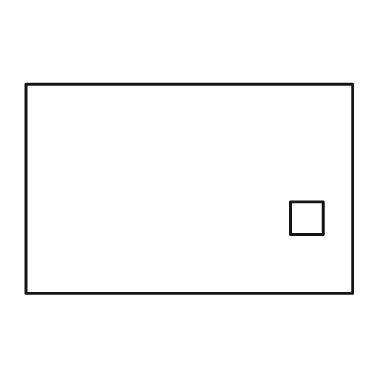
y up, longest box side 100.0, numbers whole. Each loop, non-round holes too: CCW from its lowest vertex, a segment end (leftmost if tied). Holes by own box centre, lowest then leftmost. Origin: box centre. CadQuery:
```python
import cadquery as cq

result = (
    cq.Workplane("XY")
    .moveTo(-50.0, -32.0)
    .lineTo(50.0, -32.0)
    .lineTo(50.0, 32.0)
    .lineTo(-50.0, 32.0)
    .close()
    .moveTo(31.0, -14.0)
    .lineTo(41.0, -14.0)
    .lineTo(41.0, -4.0)
    .lineTo(31.0, -4.0)
    .close()
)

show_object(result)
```